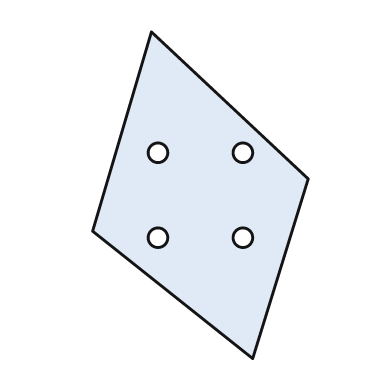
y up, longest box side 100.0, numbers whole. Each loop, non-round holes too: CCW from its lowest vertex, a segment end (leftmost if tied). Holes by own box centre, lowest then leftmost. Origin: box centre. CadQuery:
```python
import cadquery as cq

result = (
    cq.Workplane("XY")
    .moveTo(16.0, -50.0)
    .lineTo(33.0, 5.0)
    .lineTo(-15.0, 50.0)
    .lineTo(-33.0, -11.0)
    .close()
    .moveTo(-13.0, -13.0)
    .circle(3.0)
    .moveTo(13.0, -13.0)
    .circle(3.0)
    .moveTo(-13.0, 13.0)
    .circle(3.0)
    .moveTo(13.0, 13.0)
    .circle(3.0)
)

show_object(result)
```